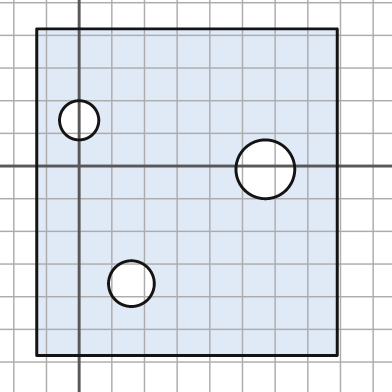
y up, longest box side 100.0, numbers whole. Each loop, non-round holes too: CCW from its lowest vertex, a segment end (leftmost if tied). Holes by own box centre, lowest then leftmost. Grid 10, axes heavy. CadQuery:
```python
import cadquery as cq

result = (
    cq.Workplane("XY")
    .moveTo(-13.0, -58.0)
    .lineTo(79.0, -58.0)
    .lineTo(79.0, 42.0)
    .lineTo(-13.0, 42.0)
    .close()
    .moveTo(16.0, -36.0)
    .circle(7.0)
    .moveTo(57.0, -1.0)
    .circle(9.0)
    .moveTo(0.0, 14.0)
    .circle(6.0)
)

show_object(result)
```